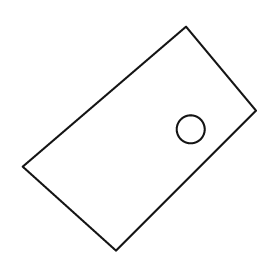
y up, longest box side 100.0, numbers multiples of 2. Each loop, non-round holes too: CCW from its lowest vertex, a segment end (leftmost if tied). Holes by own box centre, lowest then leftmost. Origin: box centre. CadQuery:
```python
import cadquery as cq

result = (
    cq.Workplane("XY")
    .moveTo(-10.0, -48.0)
    .lineTo(50.0, 12.0)
    .lineTo(20.0, 48.0)
    .lineTo(-50.0, -12.0)
    .close()
    .moveTo(22.0, 4.0)
    .circle(6.0)
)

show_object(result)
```